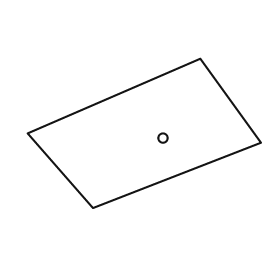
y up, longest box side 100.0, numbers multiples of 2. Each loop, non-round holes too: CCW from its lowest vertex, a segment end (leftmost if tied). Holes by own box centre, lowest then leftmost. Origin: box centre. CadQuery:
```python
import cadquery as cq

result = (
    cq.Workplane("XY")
    .moveTo(-22.0, -32.0)
    .lineTo(50.0, -4.0)
    .lineTo(24.0, 32.0)
    .lineTo(-50.0, 0.0)
    .close()
    .moveTo(8.0, -2.0)
    .circle(2.0)
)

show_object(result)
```